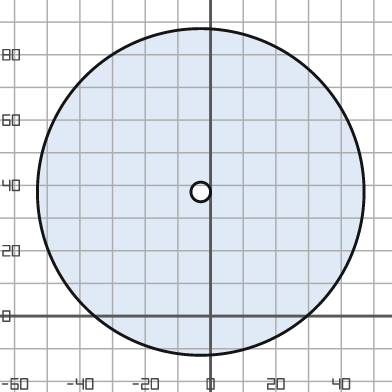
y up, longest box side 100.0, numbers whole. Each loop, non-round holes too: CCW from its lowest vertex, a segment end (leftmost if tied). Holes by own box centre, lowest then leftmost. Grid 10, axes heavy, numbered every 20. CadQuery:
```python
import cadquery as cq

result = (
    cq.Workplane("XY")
    .moveTo(-3.0, 38.0)
    .circle(50.0)
    .moveTo(-3.0, 38.0)
    .circle(3.0)
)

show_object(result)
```